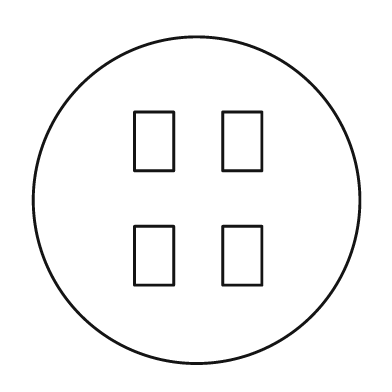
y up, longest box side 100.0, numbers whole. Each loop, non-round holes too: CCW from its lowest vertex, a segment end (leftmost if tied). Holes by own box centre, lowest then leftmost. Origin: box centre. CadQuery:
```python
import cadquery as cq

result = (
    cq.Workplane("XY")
    .moveTo(0.0, 0.0)
    .circle(50.0)
    .moveTo(-19.0, -26.0)
    .lineTo(-7.0, -26.0)
    .lineTo(-7.0, -8.0)
    .lineTo(-19.0, -8.0)
    .close()
    .moveTo(8.0, -26.0)
    .lineTo(20.0, -26.0)
    .lineTo(20.0, -8.0)
    .lineTo(8.0, -8.0)
    .close()
    .moveTo(-19.0, 9.0)
    .lineTo(-7.0, 9.0)
    .lineTo(-7.0, 27.0)
    .lineTo(-19.0, 27.0)
    .close()
    .moveTo(8.0, 9.0)
    .lineTo(20.0, 9.0)
    .lineTo(20.0, 27.0)
    .lineTo(8.0, 27.0)
    .close()
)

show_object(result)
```